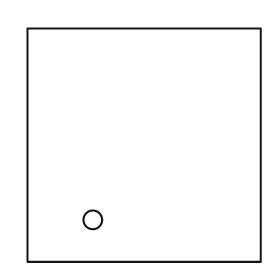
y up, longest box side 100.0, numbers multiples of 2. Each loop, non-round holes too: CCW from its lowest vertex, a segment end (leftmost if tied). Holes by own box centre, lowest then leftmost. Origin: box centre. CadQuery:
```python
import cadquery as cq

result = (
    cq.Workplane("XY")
    .moveTo(-50.0, -50.0)
    .lineTo(50.0, -50.0)
    .lineTo(50.0, 50.0)
    .lineTo(-50.0, 50.0)
    .close()
    .moveTo(-22.0, -32.0)
    .circle(4.0)
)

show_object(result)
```